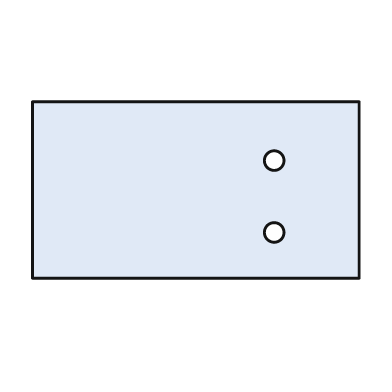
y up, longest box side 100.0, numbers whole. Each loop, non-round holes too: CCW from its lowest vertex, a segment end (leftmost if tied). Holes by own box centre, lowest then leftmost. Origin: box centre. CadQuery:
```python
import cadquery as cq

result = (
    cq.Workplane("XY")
    .moveTo(-50.0, -27.0)
    .lineTo(50.0, -27.0)
    .lineTo(50.0, 27.0)
    .lineTo(-50.0, 27.0)
    .close()
    .moveTo(24.0, -13.0)
    .circle(3.0)
    .moveTo(24.0, 9.0)
    .circle(3.0)
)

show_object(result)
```